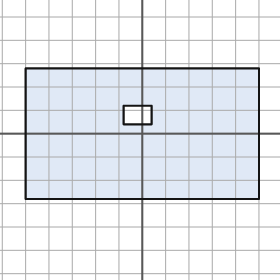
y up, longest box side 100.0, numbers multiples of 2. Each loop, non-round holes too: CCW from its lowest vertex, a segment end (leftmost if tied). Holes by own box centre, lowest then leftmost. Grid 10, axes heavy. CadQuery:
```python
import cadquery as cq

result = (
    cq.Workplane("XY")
    .moveTo(-50.0, -28.0)
    .lineTo(50.0, -28.0)
    .lineTo(50.0, 28.0)
    .lineTo(-50.0, 28.0)
    .close()
    .moveTo(-8.0, 4.0)
    .lineTo(4.0, 4.0)
    .lineTo(4.0, 12.0)
    .lineTo(-8.0, 12.0)
    .close()
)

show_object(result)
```